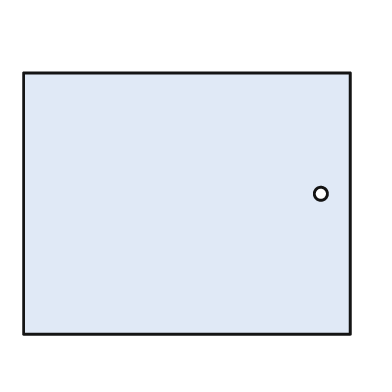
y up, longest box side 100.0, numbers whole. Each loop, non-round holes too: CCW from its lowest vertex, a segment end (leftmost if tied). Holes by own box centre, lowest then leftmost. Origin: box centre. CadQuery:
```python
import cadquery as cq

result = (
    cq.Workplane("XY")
    .moveTo(-50.0, -40.0)
    .lineTo(50.0, -40.0)
    .lineTo(50.0, 40.0)
    .lineTo(-50.0, 40.0)
    .close()
    .moveTo(41.0, 3.0)
    .circle(2.0)
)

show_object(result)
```